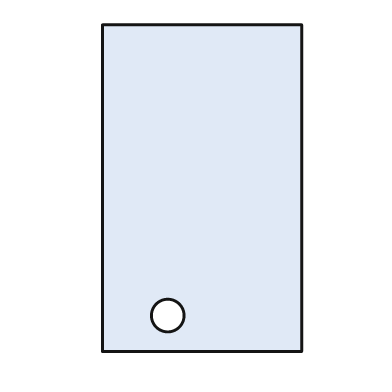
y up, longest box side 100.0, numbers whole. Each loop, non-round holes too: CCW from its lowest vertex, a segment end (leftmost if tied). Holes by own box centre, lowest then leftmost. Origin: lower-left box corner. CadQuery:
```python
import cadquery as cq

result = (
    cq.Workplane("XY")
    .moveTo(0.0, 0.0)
    .lineTo(61.0, 0.0)
    .lineTo(61.0, 100.0)
    .lineTo(0.0, 100.0)
    .close()
    .moveTo(20.0, 11.0)
    .circle(5.0)
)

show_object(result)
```